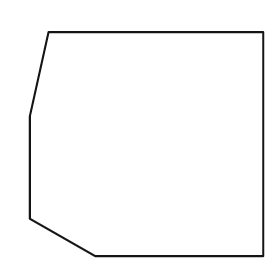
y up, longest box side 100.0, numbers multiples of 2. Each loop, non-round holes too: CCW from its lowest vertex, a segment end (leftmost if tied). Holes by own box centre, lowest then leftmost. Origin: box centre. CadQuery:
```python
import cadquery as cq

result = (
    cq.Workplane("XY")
    .moveTo(-22.0, -48.0)
    .lineTo(50.0, -48.0)
    .lineTo(50.0, 48.0)
    .lineTo(-42.0, 48.0)
    .lineTo(-50.0, 12.0)
    .lineTo(-50.0, -32.0)
    .close()
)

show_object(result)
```